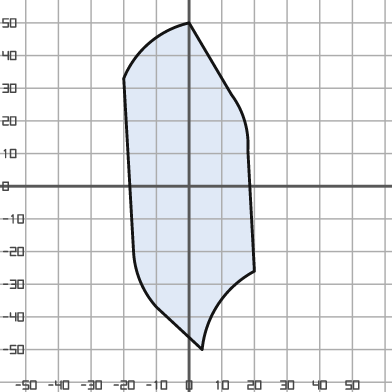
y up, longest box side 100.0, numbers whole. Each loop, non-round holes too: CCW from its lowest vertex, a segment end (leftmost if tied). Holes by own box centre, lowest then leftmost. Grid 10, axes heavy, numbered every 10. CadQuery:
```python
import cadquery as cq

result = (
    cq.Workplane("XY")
    .moveTo(4.0, -50.0)
    .threePointArc((9.0, -36.0), (20.0, -26.0))
    .lineTo(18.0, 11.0)
    .threePointArc((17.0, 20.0), (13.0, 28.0))
    .lineTo(0.0, 50.0)
    .threePointArc((-12.0, 44.0), (-20.0, 33.0))
    .lineTo(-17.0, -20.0)
    .threePointArc((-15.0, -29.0), (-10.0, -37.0))
    .close()
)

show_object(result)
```